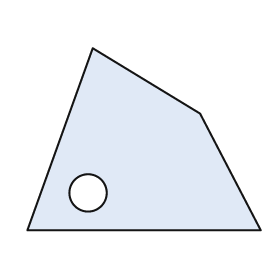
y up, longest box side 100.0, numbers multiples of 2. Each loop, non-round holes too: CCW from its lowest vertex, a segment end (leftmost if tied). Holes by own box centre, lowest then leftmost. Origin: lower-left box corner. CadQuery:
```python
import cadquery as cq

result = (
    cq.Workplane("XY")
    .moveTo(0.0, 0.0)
    .lineTo(100.0, 0.0)
    .lineTo(74.0, 50.0)
    .lineTo(28.0, 78.0)
    .close()
    .moveTo(26.0, 16.0)
    .circle(8.0)
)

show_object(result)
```